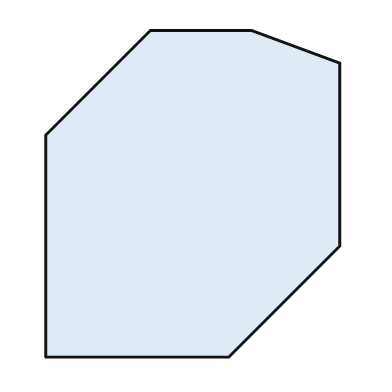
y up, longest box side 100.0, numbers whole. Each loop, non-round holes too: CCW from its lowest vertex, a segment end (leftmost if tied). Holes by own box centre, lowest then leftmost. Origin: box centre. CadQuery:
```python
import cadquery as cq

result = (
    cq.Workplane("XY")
    .moveTo(-45.0, -50.0)
    .lineTo(11.0, -50.0)
    .lineTo(45.0, -16.0)
    .lineTo(45.0, 40.0)
    .lineTo(18.0, 50.0)
    .lineTo(-13.0, 50.0)
    .lineTo(-45.0, 18.0)
    .close()
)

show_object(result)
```